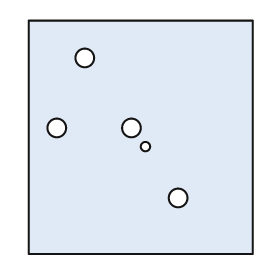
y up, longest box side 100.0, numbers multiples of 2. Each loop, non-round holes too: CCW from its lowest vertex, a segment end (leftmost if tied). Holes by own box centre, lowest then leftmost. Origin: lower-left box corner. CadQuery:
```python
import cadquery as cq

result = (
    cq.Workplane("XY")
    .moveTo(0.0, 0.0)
    .lineTo(96.0, 0.0)
    .lineTo(96.0, 100.0)
    .lineTo(0.0, 100.0)
    .close()
    .moveTo(64.0, 24.0)
    .circle(4.0)
    .moveTo(50.0, 46.0)
    .circle(2.0)
    .moveTo(12.0, 54.0)
    .circle(4.0)
    .moveTo(44.0, 54.0)
    .circle(4.0)
    .moveTo(24.0, 84.0)
    .circle(4.0)
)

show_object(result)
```